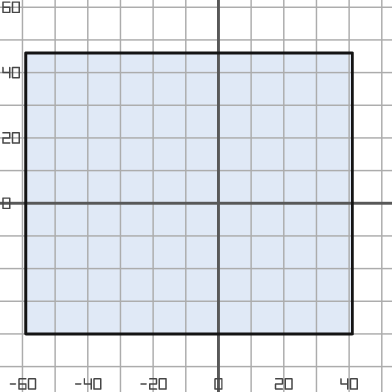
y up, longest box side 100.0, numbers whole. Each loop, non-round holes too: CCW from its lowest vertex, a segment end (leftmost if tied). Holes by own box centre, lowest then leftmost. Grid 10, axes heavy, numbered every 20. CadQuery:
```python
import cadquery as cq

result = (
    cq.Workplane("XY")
    .moveTo(-59.0, -40.0)
    .lineTo(41.0, -40.0)
    .lineTo(41.0, 46.0)
    .lineTo(-59.0, 46.0)
    .close()
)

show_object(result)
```